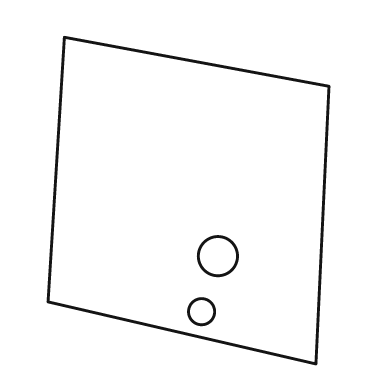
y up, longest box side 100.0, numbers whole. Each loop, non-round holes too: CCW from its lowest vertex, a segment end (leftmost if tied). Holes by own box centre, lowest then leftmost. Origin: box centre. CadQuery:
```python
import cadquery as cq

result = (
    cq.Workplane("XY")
    .moveTo(39.0, -50.0)
    .lineTo(43.0, 35.0)
    .lineTo(-38.0, 50.0)
    .lineTo(-43.0, -31.0)
    .close()
    .moveTo(4.0, -34.0)
    .circle(4.0)
    .moveTo(9.0, -17.0)
    .circle(6.0)
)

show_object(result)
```